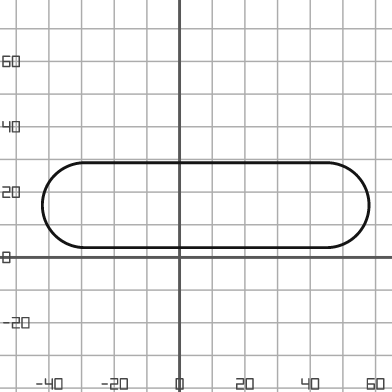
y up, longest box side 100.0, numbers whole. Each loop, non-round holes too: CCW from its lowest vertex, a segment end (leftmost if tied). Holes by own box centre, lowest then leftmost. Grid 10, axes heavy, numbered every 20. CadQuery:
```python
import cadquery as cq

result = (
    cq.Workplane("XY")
    .moveTo(-29.0, 3.0)
    .lineTo(45.0, 3.0)
    .threePointArc((58.0, 16.0), (45.0, 29.0))
    .lineTo(-29.0, 29.0)
    .threePointArc((-42.0, 16.0), (-29.0, 3.0))
    .close()
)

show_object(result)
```